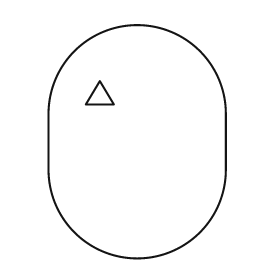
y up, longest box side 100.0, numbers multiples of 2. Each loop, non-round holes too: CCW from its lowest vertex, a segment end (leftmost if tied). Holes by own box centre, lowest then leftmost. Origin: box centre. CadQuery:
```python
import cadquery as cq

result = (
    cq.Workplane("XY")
    .moveTo(-38.0, -12.0)
    .threePointArc((0.0, -50.0), (38.0, -12.0))
    .lineTo(38.0, 12.0)
    .threePointArc((0.0, 50.0), (-38.0, 12.0))
    .close()
    .moveTo(-22.0, 16.0)
    .lineTo(-10.0, 16.0)
    .lineTo(-16.0, 26.0)
    .close()
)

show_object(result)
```